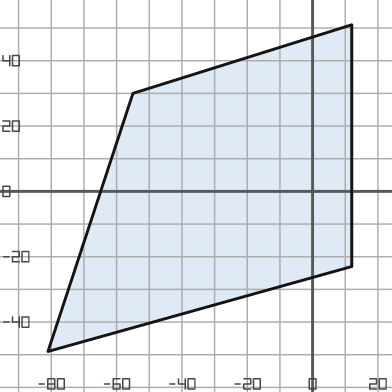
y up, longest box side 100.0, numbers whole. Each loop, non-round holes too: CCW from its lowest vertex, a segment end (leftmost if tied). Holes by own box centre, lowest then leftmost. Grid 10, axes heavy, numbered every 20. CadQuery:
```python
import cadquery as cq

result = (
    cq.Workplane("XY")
    .moveTo(-81.0, -49.0)
    .lineTo(12.0, -23.0)
    .lineTo(12.0, 51.0)
    .lineTo(-55.0, 30.0)
    .close()
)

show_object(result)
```